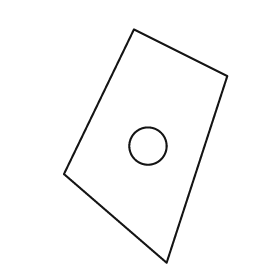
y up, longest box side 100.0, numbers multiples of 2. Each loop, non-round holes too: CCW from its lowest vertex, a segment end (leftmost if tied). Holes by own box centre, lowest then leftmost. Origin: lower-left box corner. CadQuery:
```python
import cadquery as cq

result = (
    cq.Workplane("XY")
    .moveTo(44.0, 0.0)
    .lineTo(70.0, 80.0)
    .lineTo(30.0, 100.0)
    .lineTo(0.0, 38.0)
    .close()
    .moveTo(36.0, 50.0)
    .circle(8.0)
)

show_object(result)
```